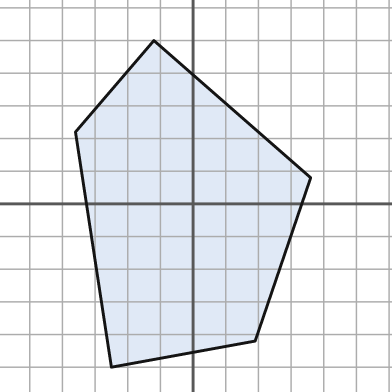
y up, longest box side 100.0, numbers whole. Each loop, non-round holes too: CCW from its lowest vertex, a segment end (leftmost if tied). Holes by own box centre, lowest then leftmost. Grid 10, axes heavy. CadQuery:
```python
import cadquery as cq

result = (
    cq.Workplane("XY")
    .moveTo(-25.0, -50.0)
    .lineTo(19.0, -42.0)
    .lineTo(36.0, 8.0)
    .lineTo(-12.0, 50.0)
    .lineTo(-36.0, 22.0)
    .close()
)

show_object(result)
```